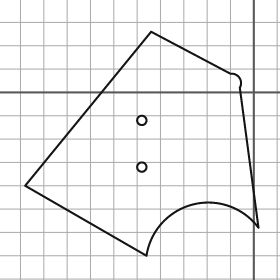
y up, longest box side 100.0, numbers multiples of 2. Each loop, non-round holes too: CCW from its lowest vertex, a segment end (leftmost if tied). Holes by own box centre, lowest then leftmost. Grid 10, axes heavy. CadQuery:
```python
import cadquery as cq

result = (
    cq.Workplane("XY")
    .moveTo(-46.0, -70.0)
    .threePointArc((-26.0, -48.0), (2.0, -58.0))
    .lineTo(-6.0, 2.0)
    .threePointArc((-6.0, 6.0), (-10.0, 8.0))
    .lineTo(-44.0, 26.0)
    .lineTo(-98.0, -40.0)
    .close()
    .moveTo(-48.0, -32.0)
    .circle(2.0)
    .moveTo(-48.0, -12.0)
    .circle(2.0)
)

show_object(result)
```